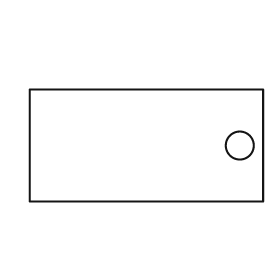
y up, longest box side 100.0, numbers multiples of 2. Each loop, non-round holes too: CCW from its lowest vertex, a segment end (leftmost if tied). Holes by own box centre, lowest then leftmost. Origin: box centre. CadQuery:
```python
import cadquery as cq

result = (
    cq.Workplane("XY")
    .moveTo(-50.0, -24.0)
    .lineTo(50.0, -24.0)
    .lineTo(50.0, 24.0)
    .lineTo(-50.0, 24.0)
    .close()
    .moveTo(40.0, 0.0)
    .circle(6.0)
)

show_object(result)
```